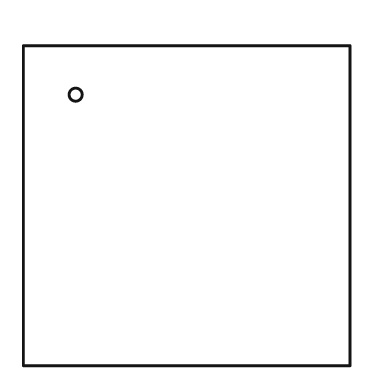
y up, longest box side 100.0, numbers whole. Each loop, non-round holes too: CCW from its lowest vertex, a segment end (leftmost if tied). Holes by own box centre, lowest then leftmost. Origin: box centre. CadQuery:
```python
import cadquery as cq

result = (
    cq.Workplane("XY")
    .moveTo(-50.0, -49.0)
    .lineTo(50.0, -49.0)
    .lineTo(50.0, 49.0)
    .lineTo(-50.0, 49.0)
    .close()
    .moveTo(-34.0, 34.0)
    .circle(2.0)
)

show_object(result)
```